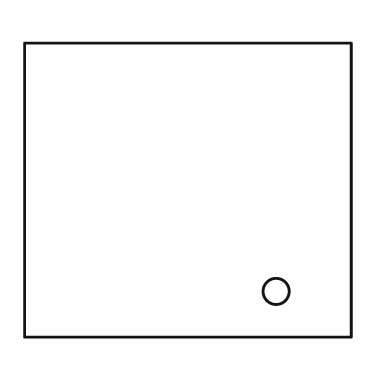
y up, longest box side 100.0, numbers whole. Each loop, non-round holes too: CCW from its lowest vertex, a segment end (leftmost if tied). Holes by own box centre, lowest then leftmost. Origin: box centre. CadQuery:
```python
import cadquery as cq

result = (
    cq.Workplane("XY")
    .moveTo(-50.0, -45.0)
    .lineTo(50.0, -45.0)
    .lineTo(50.0, 45.0)
    .lineTo(-50.0, 45.0)
    .close()
    .moveTo(27.0, -31.0)
    .circle(4.0)
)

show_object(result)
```